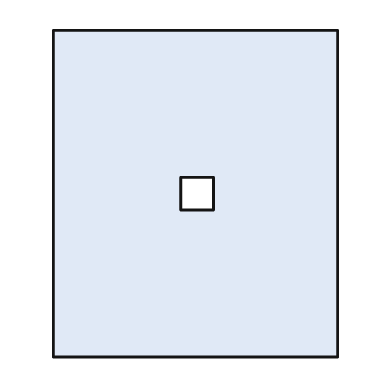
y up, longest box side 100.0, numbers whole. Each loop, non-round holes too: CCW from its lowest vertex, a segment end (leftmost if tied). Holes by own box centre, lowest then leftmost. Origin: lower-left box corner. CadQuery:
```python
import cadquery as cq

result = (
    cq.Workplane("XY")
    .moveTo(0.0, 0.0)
    .lineTo(87.0, 0.0)
    .lineTo(87.0, 100.0)
    .lineTo(0.0, 100.0)
    .close()
    .moveTo(39.0, 45.0)
    .lineTo(49.0, 45.0)
    .lineTo(49.0, 55.0)
    .lineTo(39.0, 55.0)
    .close()
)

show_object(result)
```